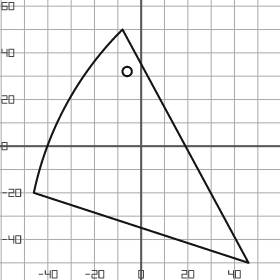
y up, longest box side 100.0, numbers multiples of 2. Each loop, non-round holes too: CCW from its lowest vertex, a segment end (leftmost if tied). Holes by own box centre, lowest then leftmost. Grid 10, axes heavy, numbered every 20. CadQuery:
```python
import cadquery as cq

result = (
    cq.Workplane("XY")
    .moveTo(46.0, -50.0)
    .lineTo(-8.0, 50.0)
    .threePointArc((-32.0, 18.0), (-46.0, -20.0))
    .close()
    .moveTo(-6.0, 32.0)
    .circle(2.0)
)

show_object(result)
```